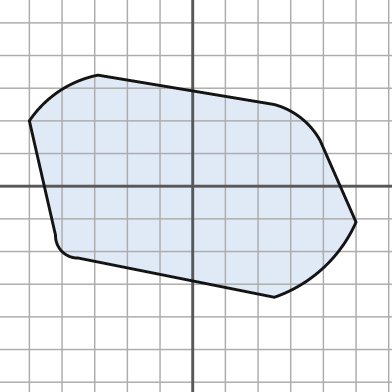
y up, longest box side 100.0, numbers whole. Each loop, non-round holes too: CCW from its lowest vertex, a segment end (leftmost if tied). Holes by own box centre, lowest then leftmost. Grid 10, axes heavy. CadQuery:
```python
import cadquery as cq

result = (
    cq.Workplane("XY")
    .moveTo(25.0, -34.0)
    .threePointArc((40.0, -25.0), (50.0, -11.0))
    .lineTo(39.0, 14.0)
    .threePointArc((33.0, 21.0), (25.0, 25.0))
    .lineTo(-29.0, 34.0)
    .threePointArc((-41.0, 29.0), (-50.0, 20.0))
    .lineTo(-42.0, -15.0)
    .threePointArc((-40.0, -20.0), (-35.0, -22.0))
    .close()
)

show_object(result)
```